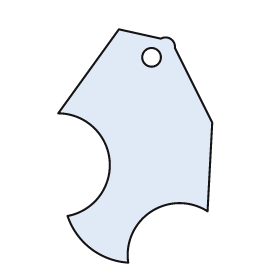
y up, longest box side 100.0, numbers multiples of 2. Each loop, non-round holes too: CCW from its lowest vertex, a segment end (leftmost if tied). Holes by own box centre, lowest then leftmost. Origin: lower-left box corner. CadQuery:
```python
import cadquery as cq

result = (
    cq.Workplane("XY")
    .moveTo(30.0, 0.0)
    .threePointArc((40.0, 22.0), (64.0, 22.0))
    .lineTo(66.0, 60.0)
    .lineTo(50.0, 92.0)
    .threePointArc((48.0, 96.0), (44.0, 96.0))
    .lineTo(26.0, 100.0)
    .lineTo(0.0, 64.0)
    .threePointArc((22.0, 44.0), (4.0, 20.0))
    .threePointArc((14.0, 6.0), (30.0, 0.0))
    .close()
    .moveTo(40.0, 88.0)
    .circle(4.0)
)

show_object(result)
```